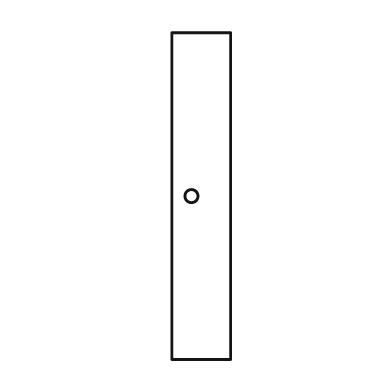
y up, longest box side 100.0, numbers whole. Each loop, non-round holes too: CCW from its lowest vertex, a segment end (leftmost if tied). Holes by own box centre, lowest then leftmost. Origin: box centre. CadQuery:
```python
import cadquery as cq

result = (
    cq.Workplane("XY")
    .moveTo(-9.0, -50.0)
    .lineTo(9.0, -50.0)
    .lineTo(9.0, 50.0)
    .lineTo(-9.0, 50.0)
    .close()
    .moveTo(-3.0, 0.0)
    .circle(2.0)
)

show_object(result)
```